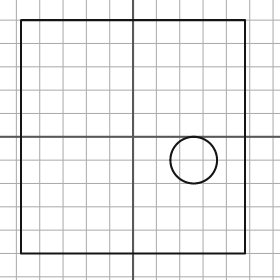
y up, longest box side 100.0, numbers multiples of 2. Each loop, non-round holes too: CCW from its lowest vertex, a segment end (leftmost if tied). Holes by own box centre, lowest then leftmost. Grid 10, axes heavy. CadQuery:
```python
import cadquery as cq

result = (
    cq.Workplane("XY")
    .moveTo(-48.0, -50.0)
    .lineTo(48.0, -50.0)
    .lineTo(48.0, 50.0)
    .lineTo(-48.0, 50.0)
    .close()
    .moveTo(26.0, -10.0)
    .circle(10.0)
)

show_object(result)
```